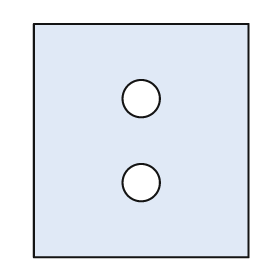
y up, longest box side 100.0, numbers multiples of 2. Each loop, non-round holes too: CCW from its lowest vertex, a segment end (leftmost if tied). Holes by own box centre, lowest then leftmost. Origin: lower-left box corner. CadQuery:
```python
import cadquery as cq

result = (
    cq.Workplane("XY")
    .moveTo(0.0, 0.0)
    .lineTo(92.0, 0.0)
    .lineTo(92.0, 100.0)
    .lineTo(0.0, 100.0)
    .close()
    .moveTo(46.0, 32.0)
    .circle(8.0)
    .moveTo(46.0, 68.0)
    .circle(8.0)
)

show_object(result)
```